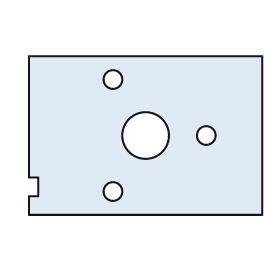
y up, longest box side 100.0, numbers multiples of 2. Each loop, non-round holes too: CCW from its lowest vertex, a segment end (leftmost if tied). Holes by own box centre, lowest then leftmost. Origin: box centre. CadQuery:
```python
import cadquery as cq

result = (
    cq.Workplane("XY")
    .moveTo(-50.0, -34.0)
    .lineTo(50.0, -34.0)
    .lineTo(50.0, 34.0)
    .lineTo(-50.0, 34.0)
    .lineTo(-50.0, -18.0)
    .lineTo(-46.0, -18.0)
    .lineTo(-46.0, -26.0)
    .lineTo(-50.0, -26.0)
    .close()
    .moveTo(-14.0, -24.0)
    .circle(4.0)
    .moveTo(0.0, 0.0)
    .circle(10.0)
    .moveTo(26.0, 0.0)
    .circle(4.0)
    .moveTo(-14.0, 24.0)
    .circle(4.0)
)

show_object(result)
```